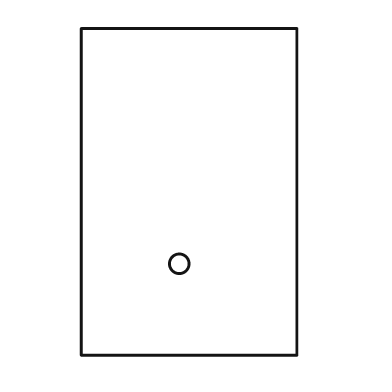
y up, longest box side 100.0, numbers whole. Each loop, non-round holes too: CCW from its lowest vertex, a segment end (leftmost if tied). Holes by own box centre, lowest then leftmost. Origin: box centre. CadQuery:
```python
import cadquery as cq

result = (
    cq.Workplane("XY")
    .moveTo(-33.0, -50.0)
    .lineTo(33.0, -50.0)
    .lineTo(33.0, 50.0)
    .lineTo(-33.0, 50.0)
    .close()
    .moveTo(-3.0, -22.0)
    .circle(3.0)
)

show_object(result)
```